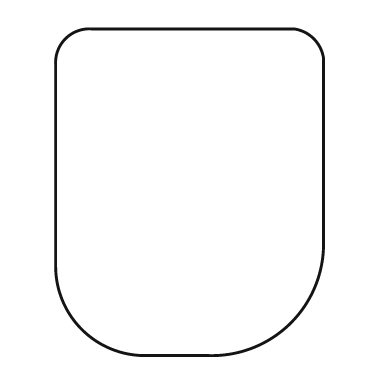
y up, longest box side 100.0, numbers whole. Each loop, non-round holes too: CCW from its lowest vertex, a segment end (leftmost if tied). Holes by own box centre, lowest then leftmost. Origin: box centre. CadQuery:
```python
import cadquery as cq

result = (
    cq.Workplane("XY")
    .moveTo(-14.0, -50.0)
    .lineTo(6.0, -50.0)
    .threePointArc((31.0, -40.0), (41.0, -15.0))
    .lineTo(41.0, 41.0)
    .threePointArc((38.0, 47.0), (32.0, 50.0))
    .lineTo(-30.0, 50.0)
    .threePointArc((-38.0, 47.0), (-41.0, 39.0))
    .lineTo(-41.0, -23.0)
    .threePointArc((-33.0, -42.0), (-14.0, -50.0))
    .close()
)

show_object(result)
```